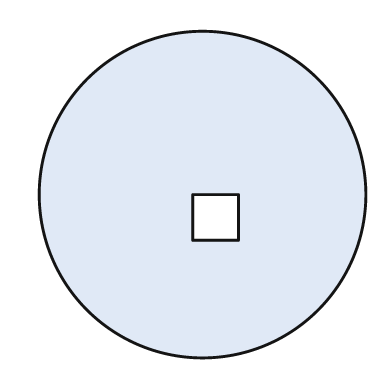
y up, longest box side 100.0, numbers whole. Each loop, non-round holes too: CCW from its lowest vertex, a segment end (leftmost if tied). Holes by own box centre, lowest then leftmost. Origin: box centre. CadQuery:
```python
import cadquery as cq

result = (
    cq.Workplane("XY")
    .moveTo(0.0, 0.0)
    .circle(50.0)
    .moveTo(-3.0, -14.0)
    .lineTo(11.0, -14.0)
    .lineTo(11.0, 0.0)
    .lineTo(-3.0, 0.0)
    .close()
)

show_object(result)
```